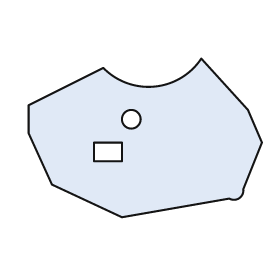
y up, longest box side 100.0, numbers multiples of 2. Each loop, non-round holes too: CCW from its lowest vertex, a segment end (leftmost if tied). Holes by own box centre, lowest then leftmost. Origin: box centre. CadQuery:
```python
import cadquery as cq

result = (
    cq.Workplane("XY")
    .moveTo(-10.0, -34.0)
    .lineTo(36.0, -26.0)
    .threePointArc((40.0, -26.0), (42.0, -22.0))
    .lineTo(50.0, -2.0)
    .lineTo(44.0, 12.0)
    .lineTo(24.0, 34.0)
    .threePointArc((4.0, 22.0), (-18.0, 30.0))
    .lineTo(-50.0, 14.0)
    .lineTo(-50.0, 2.0)
    .lineTo(-40.0, -20.0)
    .close()
    .moveTo(-22.0, -10.0)
    .lineTo(-10.0, -10.0)
    .lineTo(-10.0, -2.0)
    .lineTo(-22.0, -2.0)
    .close()
    .moveTo(-6.0, 8.0)
    .circle(4.0)
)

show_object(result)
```